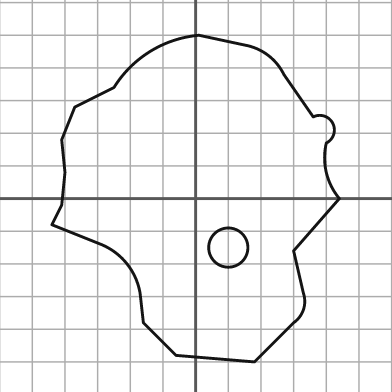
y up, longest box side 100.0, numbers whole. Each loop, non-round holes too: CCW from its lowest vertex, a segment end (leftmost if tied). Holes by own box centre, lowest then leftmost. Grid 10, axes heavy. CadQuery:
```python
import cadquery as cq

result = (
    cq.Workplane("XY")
    .moveTo(18.0, -50.0)
    .lineTo(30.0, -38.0)
    .threePointArc((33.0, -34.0), (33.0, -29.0))
    .lineTo(30.0, -16.0)
    .lineTo(44.0, 0.0)
    .threePointArc((40.0, 8.0), (40.0, 17.0))
    .threePointArc((42.0, 23.0), (36.0, 25.0))
    .lineTo(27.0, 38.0)
    .threePointArc((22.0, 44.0), (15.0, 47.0))
    .lineTo(1.0, 50.0)
    .threePointArc((-14.0, 45.0), (-25.0, 34.0))
    .lineTo(-37.0, 28.0)
    .lineTo(-41.0, 18.0)
    .lineTo(-40.0, 8.0)
    .lineTo(-41.0, -2.0)
    .lineTo(-44.0, -8.0)
    .lineTo(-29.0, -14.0)
    .threePointArc((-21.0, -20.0), (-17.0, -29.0))
    .lineTo(-16.0, -38.0)
    .lineTo(-6.0, -48.0)
    .close()
    .moveTo(10.0, -15.0)
    .circle(6.0)
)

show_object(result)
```